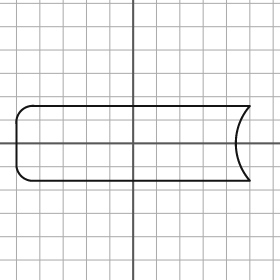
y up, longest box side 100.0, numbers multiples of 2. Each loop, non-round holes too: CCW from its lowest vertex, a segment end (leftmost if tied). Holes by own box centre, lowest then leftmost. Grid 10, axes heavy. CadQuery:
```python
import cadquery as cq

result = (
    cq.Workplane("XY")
    .moveTo(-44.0, -16.0)
    .lineTo(50.0, -16.0)
    .threePointArc((44.0, 0.0), (50.0, 16.0))
    .lineTo(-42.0, 16.0)
    .threePointArc((-48.0, 14.0), (-50.0, 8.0))
    .lineTo(-50.0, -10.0)
    .threePointArc((-48.0, -14.0), (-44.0, -16.0))
    .close()
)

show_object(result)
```